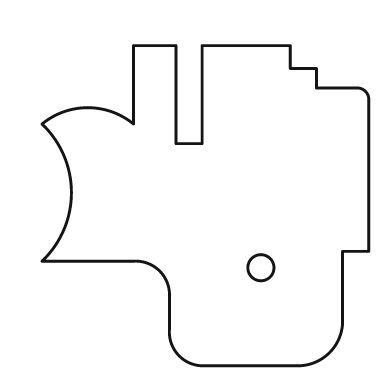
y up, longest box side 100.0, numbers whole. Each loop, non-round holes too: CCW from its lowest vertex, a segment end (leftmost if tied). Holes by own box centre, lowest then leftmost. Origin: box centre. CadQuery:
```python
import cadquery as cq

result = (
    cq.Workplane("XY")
    .moveTo(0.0, -49.0)
    .lineTo(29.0, -49.0)
    .threePointArc((38.0, -45.0), (42.0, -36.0))
    .lineTo(42.0, -14.0)
    .lineTo(50.0, -14.0)
    .lineTo(50.0, 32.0)
    .threePointArc((49.0, 35.0), (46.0, 36.0))
    .lineTo(34.0, 36.0)
    .lineTo(34.0, 42.0)
    .lineTo(26.0, 42.0)
    .lineTo(26.0, 49.0)
    .lineTo(-1.0, 49.0)
    .lineTo(-1.0, 19.0)
    .lineTo(-9.0, 19.0)
    .lineTo(-9.0, 49.0)
    .lineTo(-22.0, 49.0)
    .lineTo(-22.0, 25.0)
    .threePointArc((-36.0, 30.0), (-50.0, 25.0))
    .threePointArc((-41.0, 4.0), (-50.0, -17.0))
    .lineTo(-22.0, -17.0)
    .threePointArc((-14.0, -20.0), (-11.0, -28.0))
    .lineTo(-11.0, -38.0)
    .threePointArc((-8.0, -46.0), (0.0, -49.0))
    .close()
    .moveTo(17.0, -19.0)
    .circle(4.0)
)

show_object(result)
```